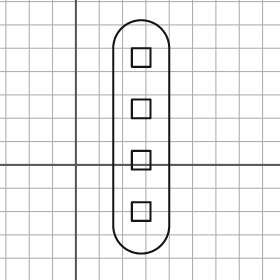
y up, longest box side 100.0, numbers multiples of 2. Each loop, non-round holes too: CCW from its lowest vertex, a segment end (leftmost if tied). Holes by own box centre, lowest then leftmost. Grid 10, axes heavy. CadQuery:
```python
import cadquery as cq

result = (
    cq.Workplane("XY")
    .moveTo(16.0, -26.0)
    .threePointArc((28.0, -38.0), (40.0, -26.0))
    .lineTo(40.0, 50.0)
    .threePointArc((28.0, 62.0), (16.0, 50.0))
    .close()
    .moveTo(24.0, -24.0)
    .lineTo(32.0, -24.0)
    .lineTo(32.0, -16.0)
    .lineTo(24.0, -16.0)
    .close()
    .moveTo(24.0, -2.0)
    .lineTo(32.0, -2.0)
    .lineTo(32.0, 6.0)
    .lineTo(24.0, 6.0)
    .close()
    .moveTo(24.0, 20.0)
    .lineTo(32.0, 20.0)
    .lineTo(32.0, 28.0)
    .lineTo(24.0, 28.0)
    .close()
    .moveTo(24.0, 42.0)
    .lineTo(32.0, 42.0)
    .lineTo(32.0, 50.0)
    .lineTo(24.0, 50.0)
    .close()
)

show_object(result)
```